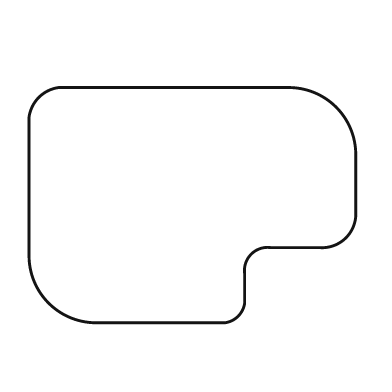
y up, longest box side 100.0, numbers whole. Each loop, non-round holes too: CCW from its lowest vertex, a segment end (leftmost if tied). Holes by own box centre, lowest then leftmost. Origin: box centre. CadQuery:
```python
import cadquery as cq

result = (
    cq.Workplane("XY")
    .moveTo(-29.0, -36.0)
    .lineTo(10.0, -36.0)
    .threePointArc((14.0, -34.0), (16.0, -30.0))
    .lineTo(16.0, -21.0)
    .threePointArc((18.0, -15.0), (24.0, -13.0))
    .lineTo(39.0, -13.0)
    .threePointArc((47.0, -10.0), (50.0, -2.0))
    .lineTo(50.0, 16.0)
    .threePointArc((44.0, 30.0), (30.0, 36.0))
    .lineTo(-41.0, 36.0)
    .threePointArc((-47.0, 33.0), (-50.0, 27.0))
    .lineTo(-50.0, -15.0)
    .threePointArc((-44.0, -30.0), (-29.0, -36.0))
    .close()
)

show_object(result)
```